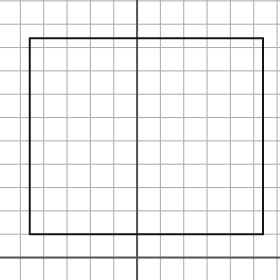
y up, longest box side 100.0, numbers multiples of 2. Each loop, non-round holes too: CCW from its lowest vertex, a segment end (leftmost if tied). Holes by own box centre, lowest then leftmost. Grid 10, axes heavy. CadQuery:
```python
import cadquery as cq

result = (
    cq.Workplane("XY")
    .moveTo(-46.0, 10.0)
    .lineTo(54.0, 10.0)
    .lineTo(54.0, 94.0)
    .lineTo(-46.0, 94.0)
    .close()
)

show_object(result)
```